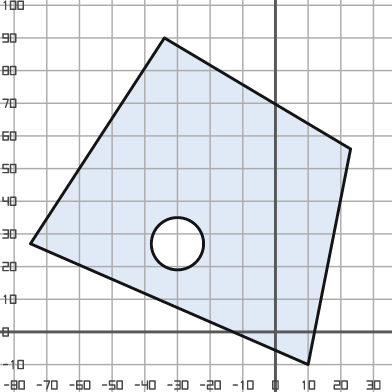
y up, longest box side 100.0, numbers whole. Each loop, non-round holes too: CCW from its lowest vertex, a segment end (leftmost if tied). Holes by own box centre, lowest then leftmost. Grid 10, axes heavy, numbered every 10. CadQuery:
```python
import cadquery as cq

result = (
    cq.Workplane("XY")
    .moveTo(10.0, -10.0)
    .lineTo(23.0, 56.0)
    .lineTo(-34.0, 90.0)
    .lineTo(-75.0, 27.0)
    .close()
    .moveTo(-30.0, 27.0)
    .circle(8.0)
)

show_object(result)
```